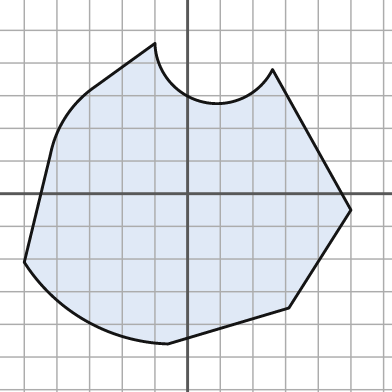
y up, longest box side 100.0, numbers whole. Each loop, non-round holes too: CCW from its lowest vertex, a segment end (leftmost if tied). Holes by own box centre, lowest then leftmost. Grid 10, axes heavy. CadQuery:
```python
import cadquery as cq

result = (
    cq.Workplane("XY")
    .moveTo(-6.0, -46.0)
    .lineTo(31.0, -35.0)
    .lineTo(50.0, -5.0)
    .lineTo(26.0, 38.0)
    .threePointArc((5.0, 28.0), (-10.0, 46.0))
    .lineTo(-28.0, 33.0)
    .threePointArc((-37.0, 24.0), (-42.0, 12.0))
    .lineTo(-50.0, -21.0)
    .threePointArc((-31.0, -39.0), (-6.0, -46.0))
    .close()
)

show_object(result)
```